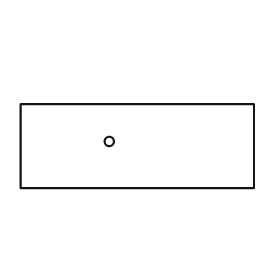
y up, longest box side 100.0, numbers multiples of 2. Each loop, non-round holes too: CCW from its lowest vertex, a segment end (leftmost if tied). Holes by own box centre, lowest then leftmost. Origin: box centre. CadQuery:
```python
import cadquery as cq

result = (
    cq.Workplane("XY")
    .moveTo(-50.0, -18.0)
    .lineTo(50.0, -18.0)
    .lineTo(50.0, 18.0)
    .lineTo(-50.0, 18.0)
    .close()
    .moveTo(-12.0, 2.0)
    .circle(2.0)
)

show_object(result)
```